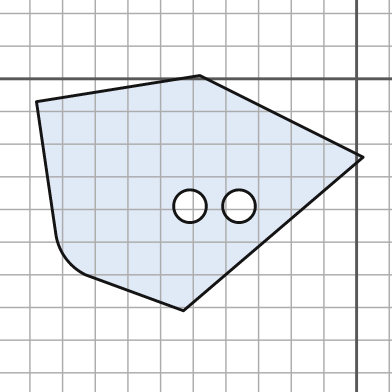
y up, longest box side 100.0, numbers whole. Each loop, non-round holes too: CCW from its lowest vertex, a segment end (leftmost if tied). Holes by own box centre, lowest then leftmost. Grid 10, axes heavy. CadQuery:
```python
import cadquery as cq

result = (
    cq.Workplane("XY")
    .moveTo(-53.0, -71.0)
    .lineTo(2.0, -24.0)
    .lineTo(-48.0, 1.0)
    .lineTo(-98.0, -7.0)
    .lineTo(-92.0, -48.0)
    .threePointArc((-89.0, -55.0), (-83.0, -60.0))
    .close()
    .moveTo(-51.0, -39.0)
    .circle(5.0)
    .moveTo(-36.0, -39.0)
    .circle(5.0)
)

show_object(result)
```